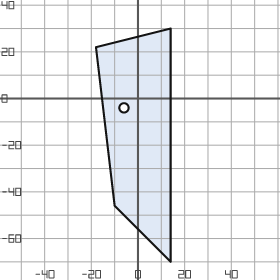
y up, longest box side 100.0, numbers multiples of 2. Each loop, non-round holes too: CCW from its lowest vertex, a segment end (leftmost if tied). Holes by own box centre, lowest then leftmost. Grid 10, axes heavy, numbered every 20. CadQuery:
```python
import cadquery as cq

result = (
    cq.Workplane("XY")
    .moveTo(14.0, -70.0)
    .lineTo(14.0, 30.0)
    .lineTo(-18.0, 22.0)
    .lineTo(-10.0, -46.0)
    .close()
    .moveTo(-6.0, -4.0)
    .circle(2.0)
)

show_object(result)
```